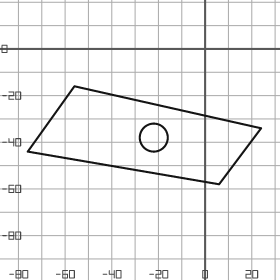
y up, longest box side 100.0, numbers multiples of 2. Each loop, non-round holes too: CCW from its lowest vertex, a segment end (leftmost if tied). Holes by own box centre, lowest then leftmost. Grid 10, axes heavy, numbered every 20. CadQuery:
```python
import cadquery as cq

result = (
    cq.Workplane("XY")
    .moveTo(6.0, -58.0)
    .lineTo(24.0, -34.0)
    .lineTo(-56.0, -16.0)
    .lineTo(-76.0, -44.0)
    .close()
    .moveTo(-22.0, -38.0)
    .circle(6.0)
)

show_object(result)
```